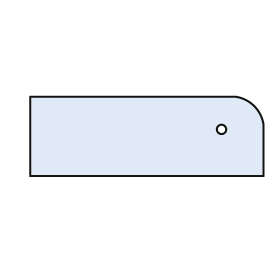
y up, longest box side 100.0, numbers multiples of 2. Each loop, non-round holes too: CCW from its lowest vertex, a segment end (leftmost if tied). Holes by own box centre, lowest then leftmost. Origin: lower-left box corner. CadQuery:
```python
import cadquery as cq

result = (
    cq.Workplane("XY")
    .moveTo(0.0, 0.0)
    .lineTo(100.0, 0.0)
    .lineTo(100.0, 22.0)
    .threePointArc((96.0, 30.0), (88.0, 34.0))
    .lineTo(0.0, 34.0)
    .close()
    .moveTo(82.0, 20.0)
    .circle(2.0)
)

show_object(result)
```